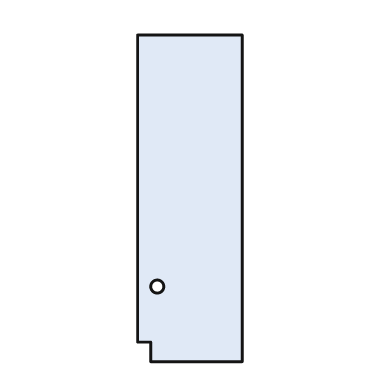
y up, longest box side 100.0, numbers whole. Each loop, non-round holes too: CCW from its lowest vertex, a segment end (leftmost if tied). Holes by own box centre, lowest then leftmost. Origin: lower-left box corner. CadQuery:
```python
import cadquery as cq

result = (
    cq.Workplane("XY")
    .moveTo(4.0, 0.0)
    .lineTo(32.0, 0.0)
    .lineTo(32.0, 100.0)
    .lineTo(0.0, 100.0)
    .lineTo(0.0, 6.0)
    .lineTo(4.0, 6.0)
    .close()
    .moveTo(6.0, 23.0)
    .circle(2.0)
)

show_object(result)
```